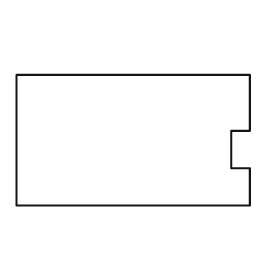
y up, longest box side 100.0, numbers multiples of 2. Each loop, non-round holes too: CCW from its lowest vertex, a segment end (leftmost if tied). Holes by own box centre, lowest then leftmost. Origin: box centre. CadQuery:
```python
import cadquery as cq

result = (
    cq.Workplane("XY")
    .moveTo(-50.0, -28.0)
    .lineTo(50.0, -28.0)
    .lineTo(50.0, -12.0)
    .lineTo(42.0, -12.0)
    .lineTo(42.0, 4.0)
    .lineTo(50.0, 4.0)
    .lineTo(50.0, 28.0)
    .lineTo(-50.0, 28.0)
    .close()
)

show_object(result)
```